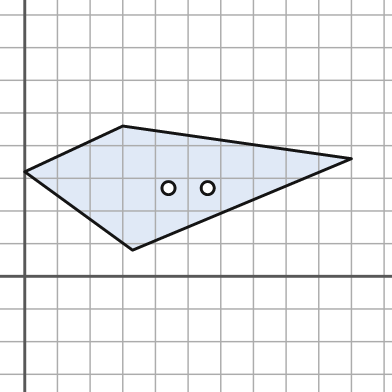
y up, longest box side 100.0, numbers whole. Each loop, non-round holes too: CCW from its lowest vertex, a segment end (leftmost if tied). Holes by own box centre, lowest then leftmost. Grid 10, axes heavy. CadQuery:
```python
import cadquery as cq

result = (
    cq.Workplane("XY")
    .moveTo(33.0, 8.0)
    .lineTo(100.0, 36.0)
    .lineTo(30.0, 46.0)
    .lineTo(0.0, 32.0)
    .close()
    .moveTo(44.0, 27.0)
    .circle(2.0)
    .moveTo(56.0, 27.0)
    .circle(2.0)
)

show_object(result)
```